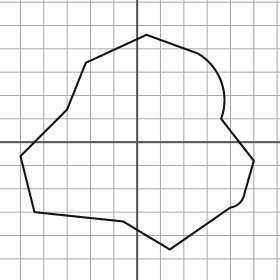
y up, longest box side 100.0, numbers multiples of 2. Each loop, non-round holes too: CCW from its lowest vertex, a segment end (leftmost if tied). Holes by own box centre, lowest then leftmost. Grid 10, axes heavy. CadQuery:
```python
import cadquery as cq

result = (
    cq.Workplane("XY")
    .moveTo(14.0, -46.0)
    .lineTo(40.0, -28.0)
    .threePointArc((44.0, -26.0), (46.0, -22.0))
    .lineTo(50.0, -8.0)
    .lineTo(36.0, 10.0)
    .threePointArc((36.0, 26.0), (26.0, 38.0))
    .lineTo(4.0, 46.0)
    .lineTo(-22.0, 34.0)
    .lineTo(-30.0, 14.0)
    .lineTo(-50.0, -6.0)
    .lineTo(-44.0, -30.0)
    .lineTo(-6.0, -34.0)
    .close()
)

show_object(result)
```